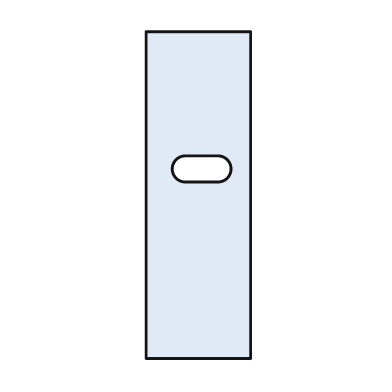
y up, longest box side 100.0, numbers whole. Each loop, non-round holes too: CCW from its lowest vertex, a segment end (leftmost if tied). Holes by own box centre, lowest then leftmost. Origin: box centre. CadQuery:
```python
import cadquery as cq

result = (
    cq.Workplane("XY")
    .moveTo(-16.0, -50.0)
    .lineTo(16.0, -50.0)
    .lineTo(16.0, 50.0)
    .lineTo(-16.0, 50.0)
    .close()
    .moveTo(-4.0, 4.0)
    .lineTo(6.0, 4.0)
    .threePointArc((10.0, 8.0), (6.0, 12.0))
    .lineTo(-4.0, 12.0)
    .threePointArc((-8.0, 8.0), (-4.0, 4.0))
    .close()
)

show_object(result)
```